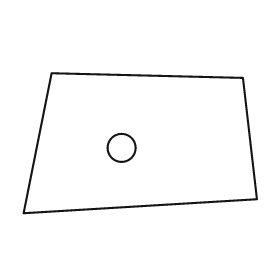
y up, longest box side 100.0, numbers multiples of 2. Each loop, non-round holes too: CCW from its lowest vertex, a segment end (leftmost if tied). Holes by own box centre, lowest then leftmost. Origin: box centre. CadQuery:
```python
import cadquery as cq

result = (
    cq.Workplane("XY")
    .moveTo(-50.0, -30.0)
    .lineTo(50.0, -24.0)
    .lineTo(44.0, 28.0)
    .lineTo(-38.0, 30.0)
    .close()
    .moveTo(-8.0, -2.0)
    .circle(6.0)
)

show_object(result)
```